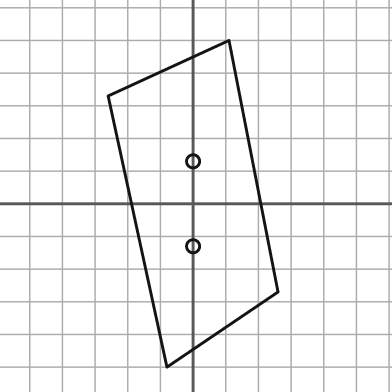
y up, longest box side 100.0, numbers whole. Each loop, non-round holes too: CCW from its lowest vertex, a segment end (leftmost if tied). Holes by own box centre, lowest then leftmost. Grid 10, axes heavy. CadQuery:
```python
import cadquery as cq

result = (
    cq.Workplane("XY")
    .moveTo(-8.0, -50.0)
    .lineTo(26.0, -27.0)
    .lineTo(11.0, 50.0)
    .lineTo(-26.0, 33.0)
    .close()
    .moveTo(0.0, -13.0)
    .circle(2.0)
    .moveTo(0.0, 13.0)
    .circle(2.0)
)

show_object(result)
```